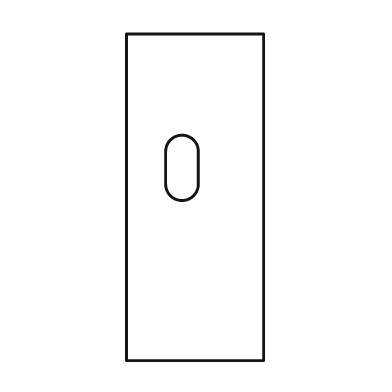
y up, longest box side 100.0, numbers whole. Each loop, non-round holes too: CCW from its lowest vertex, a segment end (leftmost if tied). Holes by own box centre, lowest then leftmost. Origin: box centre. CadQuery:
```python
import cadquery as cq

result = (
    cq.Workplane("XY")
    .moveTo(-21.0, -50.0)
    .lineTo(21.0, -50.0)
    .lineTo(21.0, 50.0)
    .lineTo(-21.0, 50.0)
    .close()
    .moveTo(-9.0, 4.0)
    .threePointArc((-4.0, -1.0), (1.0, 4.0))
    .lineTo(1.0, 14.0)
    .threePointArc((-4.0, 19.0), (-9.0, 14.0))
    .close()
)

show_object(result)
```